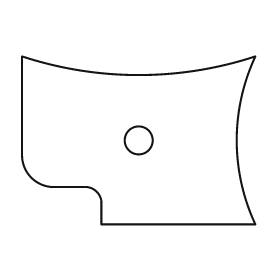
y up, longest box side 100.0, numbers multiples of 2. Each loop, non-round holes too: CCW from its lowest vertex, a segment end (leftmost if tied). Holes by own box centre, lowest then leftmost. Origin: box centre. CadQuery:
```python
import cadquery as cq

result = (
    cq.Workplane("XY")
    .moveTo(-16.0, -36.0)
    .lineTo(50.0, -36.0)
    .threePointArc((42.0, 0.0), (50.0, 36.0))
    .threePointArc((0.0, 28.0), (-50.0, 36.0))
    .lineTo(-50.0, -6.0)
    .threePointArc((-46.0, -16.0), (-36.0, -20.0))
    .lineTo(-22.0, -20.0)
    .threePointArc((-18.0, -22.0), (-16.0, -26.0))
    .close()
    .moveTo(0.0, 0.0)
    .circle(6.0)
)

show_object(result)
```